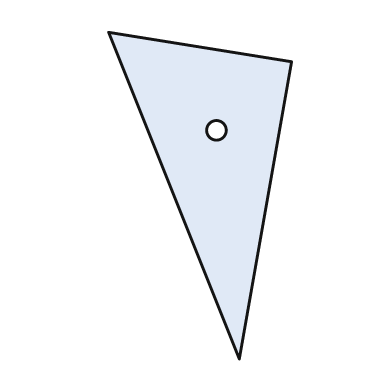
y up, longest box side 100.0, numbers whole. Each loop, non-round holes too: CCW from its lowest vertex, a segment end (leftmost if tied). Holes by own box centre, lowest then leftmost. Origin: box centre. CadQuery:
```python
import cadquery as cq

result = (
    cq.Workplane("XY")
    .moveTo(12.0, -50.0)
    .lineTo(28.0, 41.0)
    .lineTo(-28.0, 50.0)
    .close()
    .moveTo(5.0, 20.0)
    .circle(3.0)
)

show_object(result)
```